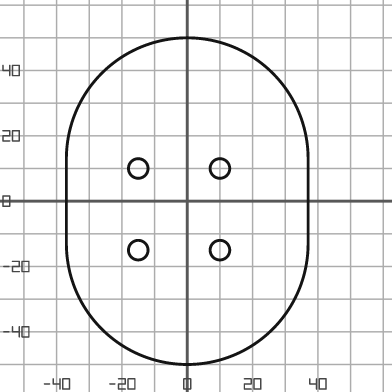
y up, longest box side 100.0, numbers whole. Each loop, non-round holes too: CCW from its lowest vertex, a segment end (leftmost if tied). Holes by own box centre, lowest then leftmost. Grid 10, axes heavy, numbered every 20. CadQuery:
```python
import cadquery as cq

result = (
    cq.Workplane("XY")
    .moveTo(-37.0, -13.0)
    .threePointArc((0.0, -50.0), (37.0, -13.0))
    .lineTo(37.0, 13.0)
    .threePointArc((0.0, 50.0), (-37.0, 13.0))
    .close()
    .moveTo(-15.0, -15.0)
    .circle(3.0)
    .moveTo(10.0, -15.0)
    .circle(3.0)
    .moveTo(-15.0, 10.0)
    .circle(3.0)
    .moveTo(10.0, 10.0)
    .circle(3.0)
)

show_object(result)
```